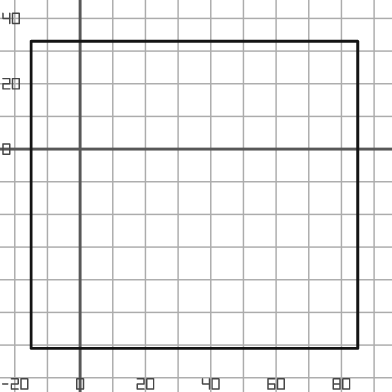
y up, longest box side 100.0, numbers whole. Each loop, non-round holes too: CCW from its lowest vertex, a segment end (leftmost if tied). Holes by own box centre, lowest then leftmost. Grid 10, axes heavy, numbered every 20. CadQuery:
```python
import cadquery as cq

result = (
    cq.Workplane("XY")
    .moveTo(-15.0, -61.0)
    .lineTo(85.0, -61.0)
    .lineTo(85.0, 33.0)
    .lineTo(-15.0, 33.0)
    .close()
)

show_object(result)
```